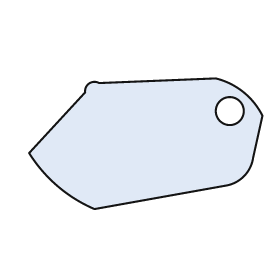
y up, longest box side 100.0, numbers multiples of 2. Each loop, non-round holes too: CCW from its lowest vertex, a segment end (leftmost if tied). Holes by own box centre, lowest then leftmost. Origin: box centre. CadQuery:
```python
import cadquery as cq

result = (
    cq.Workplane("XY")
    .moveTo(-22.0, -28.0)
    .lineTo(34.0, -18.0)
    .threePointArc((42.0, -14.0), (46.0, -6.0))
    .lineTo(50.0, 12.0)
    .threePointArc((42.0, 22.0), (30.0, 28.0))
    .lineTo(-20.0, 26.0)
    .threePointArc((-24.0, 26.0), (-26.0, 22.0))
    .lineTo(-50.0, -4.0)
    .threePointArc((-38.0, -18.0), (-22.0, -28.0))
    .close()
    .moveTo(36.0, 14.0)
    .circle(6.0)
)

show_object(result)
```